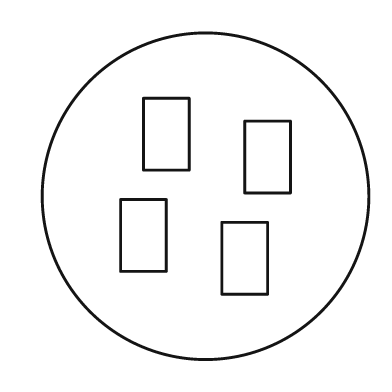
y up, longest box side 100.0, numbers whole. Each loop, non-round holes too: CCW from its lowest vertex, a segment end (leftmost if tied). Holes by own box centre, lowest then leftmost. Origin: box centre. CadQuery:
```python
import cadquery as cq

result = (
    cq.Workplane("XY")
    .moveTo(0.0, 0.0)
    .circle(50.0)
    .moveTo(5.0, -30.0)
    .lineTo(19.0, -30.0)
    .lineTo(19.0, -8.0)
    .lineTo(5.0, -8.0)
    .close()
    .moveTo(-26.0, -23.0)
    .lineTo(-12.0, -23.0)
    .lineTo(-12.0, -1.0)
    .lineTo(-26.0, -1.0)
    .close()
    .moveTo(12.0, 1.0)
    .lineTo(26.0, 1.0)
    .lineTo(26.0, 23.0)
    .lineTo(12.0, 23.0)
    .close()
    .moveTo(-19.0, 8.0)
    .lineTo(-5.0, 8.0)
    .lineTo(-5.0, 30.0)
    .lineTo(-19.0, 30.0)
    .close()
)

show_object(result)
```